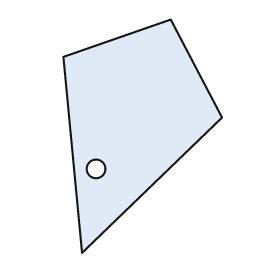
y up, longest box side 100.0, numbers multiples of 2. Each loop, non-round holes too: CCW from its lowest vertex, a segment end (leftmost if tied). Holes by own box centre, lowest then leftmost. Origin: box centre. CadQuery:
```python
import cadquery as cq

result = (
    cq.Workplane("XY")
    .moveTo(-26.0, -50.0)
    .lineTo(34.0, 8.0)
    .lineTo(12.0, 50.0)
    .lineTo(-34.0, 34.0)
    .close()
    .moveTo(-20.0, -14.0)
    .circle(4.0)
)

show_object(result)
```